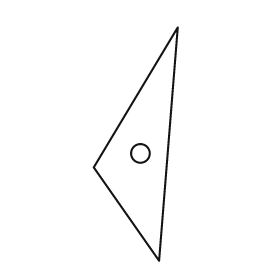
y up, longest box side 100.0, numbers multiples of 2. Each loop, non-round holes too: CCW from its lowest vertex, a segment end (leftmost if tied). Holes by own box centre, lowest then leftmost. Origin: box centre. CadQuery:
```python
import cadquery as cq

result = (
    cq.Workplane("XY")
    .moveTo(10.0, -50.0)
    .lineTo(18.0, 50.0)
    .lineTo(-18.0, -10.0)
    .close()
    .moveTo(2.0, -4.0)
    .circle(4.0)
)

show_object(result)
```